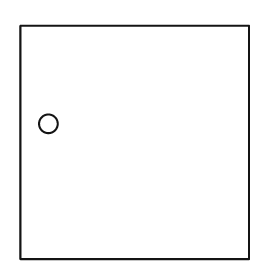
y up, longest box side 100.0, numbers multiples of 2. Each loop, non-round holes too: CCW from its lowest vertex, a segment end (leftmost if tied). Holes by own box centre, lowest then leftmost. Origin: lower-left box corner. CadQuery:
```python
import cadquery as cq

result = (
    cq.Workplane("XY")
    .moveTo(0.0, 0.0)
    .lineTo(98.0, 0.0)
    .lineTo(98.0, 100.0)
    .lineTo(0.0, 100.0)
    .close()
    .moveTo(12.0, 58.0)
    .circle(4.0)
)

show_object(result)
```